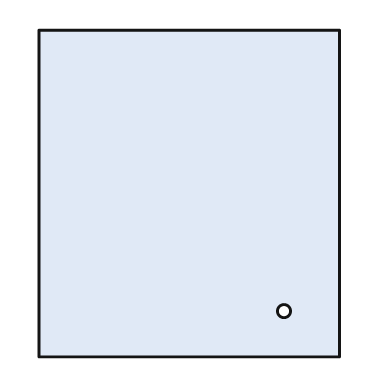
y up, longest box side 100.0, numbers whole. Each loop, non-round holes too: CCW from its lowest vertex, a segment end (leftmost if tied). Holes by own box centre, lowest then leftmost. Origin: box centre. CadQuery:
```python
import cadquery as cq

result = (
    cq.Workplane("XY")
    .moveTo(-46.0, -50.0)
    .lineTo(46.0, -50.0)
    .lineTo(46.0, 50.0)
    .lineTo(-46.0, 50.0)
    .close()
    .moveTo(29.0, -36.0)
    .circle(2.0)
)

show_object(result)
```